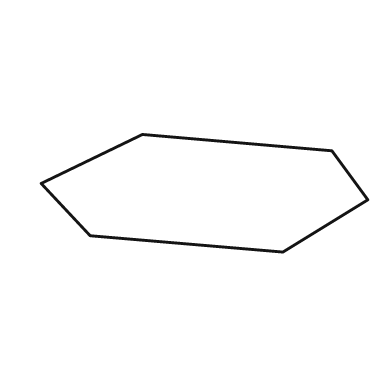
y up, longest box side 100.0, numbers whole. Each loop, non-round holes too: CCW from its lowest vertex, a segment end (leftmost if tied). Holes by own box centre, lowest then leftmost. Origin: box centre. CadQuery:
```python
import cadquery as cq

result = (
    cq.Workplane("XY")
    .moveTo(24.0, -18.0)
    .lineTo(50.0, -2.0)
    .lineTo(39.0, 13.0)
    .lineTo(-19.0, 18.0)
    .lineTo(-50.0, 3.0)
    .lineTo(-35.0, -13.0)
    .close()
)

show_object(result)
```